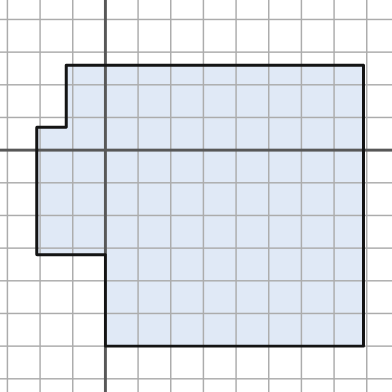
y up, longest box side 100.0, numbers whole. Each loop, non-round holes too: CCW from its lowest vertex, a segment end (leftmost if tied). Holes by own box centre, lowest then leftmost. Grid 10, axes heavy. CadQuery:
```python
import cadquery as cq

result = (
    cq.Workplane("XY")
    .moveTo(0.0, -60.0)
    .lineTo(79.0, -60.0)
    .lineTo(79.0, 26.0)
    .lineTo(-12.0, 26.0)
    .lineTo(-12.0, 7.0)
    .lineTo(-21.0, 7.0)
    .lineTo(-21.0, -32.0)
    .lineTo(0.0, -32.0)
    .close()
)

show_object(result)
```